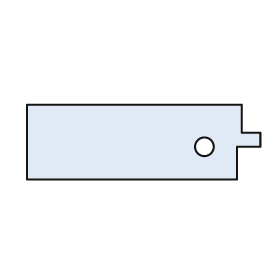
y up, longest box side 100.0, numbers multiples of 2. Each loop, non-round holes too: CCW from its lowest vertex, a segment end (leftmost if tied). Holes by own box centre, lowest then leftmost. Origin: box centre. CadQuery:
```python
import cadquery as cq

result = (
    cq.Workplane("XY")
    .moveTo(-50.0, -16.0)
    .lineTo(40.0, -16.0)
    .lineTo(40.0, -2.0)
    .lineTo(50.0, -2.0)
    .lineTo(50.0, 4.0)
    .lineTo(42.0, 4.0)
    .lineTo(42.0, 16.0)
    .lineTo(-50.0, 16.0)
    .close()
    .moveTo(26.0, -2.0)
    .circle(4.0)
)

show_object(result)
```